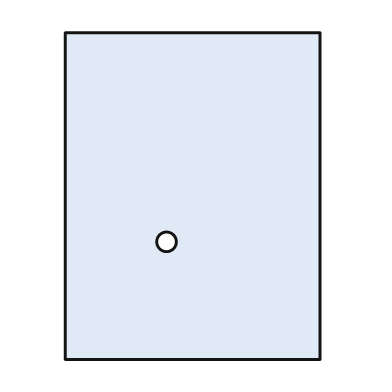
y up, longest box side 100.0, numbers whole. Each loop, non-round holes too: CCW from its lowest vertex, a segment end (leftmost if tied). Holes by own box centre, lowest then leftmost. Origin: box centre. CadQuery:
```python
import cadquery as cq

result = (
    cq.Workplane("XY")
    .moveTo(-39.0, -50.0)
    .lineTo(39.0, -50.0)
    .lineTo(39.0, 50.0)
    .lineTo(-39.0, 50.0)
    .close()
    .moveTo(-8.0, -14.0)
    .circle(3.0)
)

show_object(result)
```